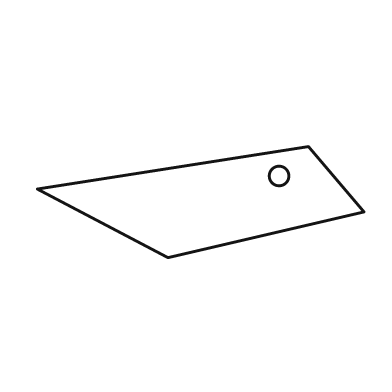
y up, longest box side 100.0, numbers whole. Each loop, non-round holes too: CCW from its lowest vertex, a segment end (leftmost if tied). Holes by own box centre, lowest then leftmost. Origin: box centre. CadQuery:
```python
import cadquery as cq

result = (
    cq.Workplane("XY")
    .moveTo(-10.0, -17.0)
    .lineTo(50.0, -3.0)
    .lineTo(33.0, 17.0)
    .lineTo(-50.0, 4.0)
    .close()
    .moveTo(24.0, 8.0)
    .circle(3.0)
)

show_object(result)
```